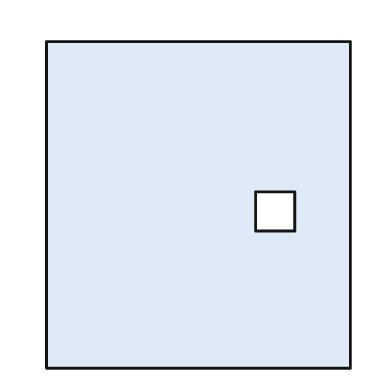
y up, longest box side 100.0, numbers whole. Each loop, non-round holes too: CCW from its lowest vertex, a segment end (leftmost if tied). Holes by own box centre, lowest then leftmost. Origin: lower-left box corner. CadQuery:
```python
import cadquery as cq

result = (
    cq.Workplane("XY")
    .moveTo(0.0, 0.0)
    .lineTo(93.0, 0.0)
    .lineTo(93.0, 100.0)
    .lineTo(0.0, 100.0)
    .close()
    .moveTo(64.0, 42.0)
    .lineTo(76.0, 42.0)
    .lineTo(76.0, 54.0)
    .lineTo(64.0, 54.0)
    .close()
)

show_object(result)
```